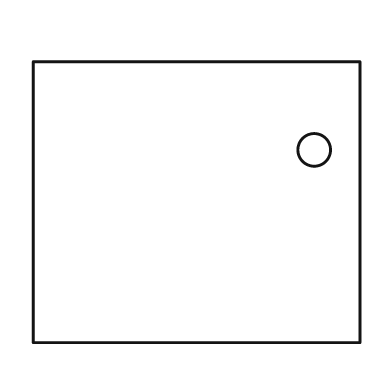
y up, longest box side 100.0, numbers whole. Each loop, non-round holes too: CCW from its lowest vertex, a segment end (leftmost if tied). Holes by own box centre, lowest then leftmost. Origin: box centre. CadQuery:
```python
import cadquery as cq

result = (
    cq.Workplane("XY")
    .moveTo(-50.0, -43.0)
    .lineTo(50.0, -43.0)
    .lineTo(50.0, 43.0)
    .lineTo(-50.0, 43.0)
    .close()
    .moveTo(36.0, 16.0)
    .circle(5.0)
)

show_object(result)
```